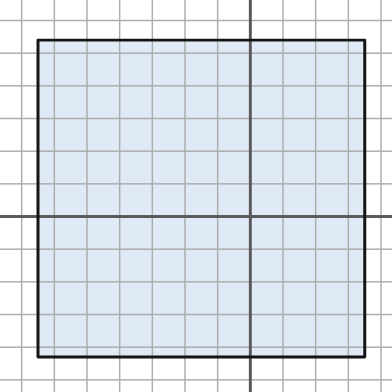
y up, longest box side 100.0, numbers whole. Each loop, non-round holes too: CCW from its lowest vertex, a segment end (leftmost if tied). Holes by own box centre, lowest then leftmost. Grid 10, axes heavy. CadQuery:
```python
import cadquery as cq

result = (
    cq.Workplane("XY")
    .moveTo(-65.0, -43.0)
    .lineTo(35.0, -43.0)
    .lineTo(35.0, 54.0)
    .lineTo(-65.0, 54.0)
    .close()
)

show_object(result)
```